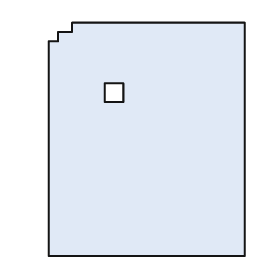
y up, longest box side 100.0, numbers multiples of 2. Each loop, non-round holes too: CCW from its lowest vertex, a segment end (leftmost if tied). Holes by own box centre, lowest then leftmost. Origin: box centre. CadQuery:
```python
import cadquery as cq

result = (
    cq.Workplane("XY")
    .moveTo(-42.0, -50.0)
    .lineTo(42.0, -50.0)
    .lineTo(42.0, 50.0)
    .lineTo(-32.0, 50.0)
    .lineTo(-32.0, 46.0)
    .lineTo(-38.0, 46.0)
    .lineTo(-38.0, 42.0)
    .lineTo(-42.0, 42.0)
    .close()
    .moveTo(-18.0, 16.0)
    .lineTo(-10.0, 16.0)
    .lineTo(-10.0, 24.0)
    .lineTo(-18.0, 24.0)
    .close()
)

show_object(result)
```